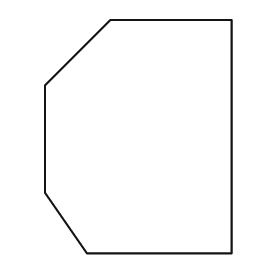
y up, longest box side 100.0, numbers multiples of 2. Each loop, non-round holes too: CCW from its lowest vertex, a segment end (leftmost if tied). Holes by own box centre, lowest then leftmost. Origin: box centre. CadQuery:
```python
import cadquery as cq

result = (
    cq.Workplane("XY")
    .moveTo(-22.0, -50.0)
    .lineTo(40.0, -50.0)
    .lineTo(40.0, 50.0)
    .lineTo(-12.0, 50.0)
    .lineTo(-40.0, 22.0)
    .lineTo(-40.0, -24.0)
    .close()
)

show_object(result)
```